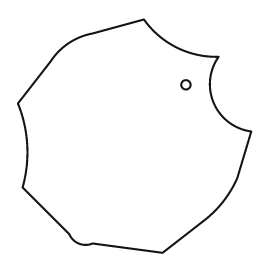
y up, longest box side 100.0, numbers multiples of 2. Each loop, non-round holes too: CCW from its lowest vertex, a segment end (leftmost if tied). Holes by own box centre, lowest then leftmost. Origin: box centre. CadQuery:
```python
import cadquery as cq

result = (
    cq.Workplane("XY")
    .moveTo(12.0, -50.0)
    .lineTo(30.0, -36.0)
    .threePointArc((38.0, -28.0), (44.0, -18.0))
    .lineTo(50.0, 2.0)
    .threePointArc((34.0, 14.0), (36.0, 34.0))
    .threePointArc((18.0, 38.0), (4.0, 50.0))
    .lineTo(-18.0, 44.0)
    .threePointArc((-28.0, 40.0), (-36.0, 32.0))
    .lineTo(-50.0, 14.0)
    .threePointArc((-46.0, -4.0), (-48.0, -22.0))
    .lineTo(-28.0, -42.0)
    .threePointArc((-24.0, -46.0), (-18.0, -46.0))
    .close()
    .moveTo(22.0, 22.0)
    .circle(2.0)
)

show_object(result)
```